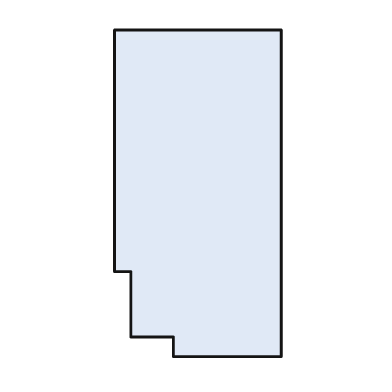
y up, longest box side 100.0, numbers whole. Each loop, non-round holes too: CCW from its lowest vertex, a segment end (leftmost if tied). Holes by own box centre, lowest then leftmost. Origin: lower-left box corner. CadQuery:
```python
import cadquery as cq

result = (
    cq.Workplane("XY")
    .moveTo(18.0, 0.0)
    .lineTo(51.0, 0.0)
    .lineTo(51.0, 100.0)
    .lineTo(0.0, 100.0)
    .lineTo(0.0, 26.0)
    .lineTo(5.0, 26.0)
    .lineTo(5.0, 6.0)
    .lineTo(18.0, 6.0)
    .close()
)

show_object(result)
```